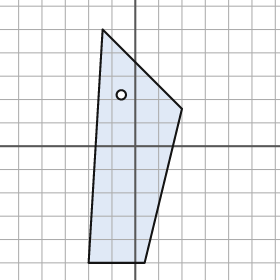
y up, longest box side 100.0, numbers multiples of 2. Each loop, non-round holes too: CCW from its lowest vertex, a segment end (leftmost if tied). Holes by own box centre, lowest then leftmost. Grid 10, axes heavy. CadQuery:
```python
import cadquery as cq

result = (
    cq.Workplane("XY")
    .moveTo(-20.0, -50.0)
    .lineTo(4.0, -50.0)
    .lineTo(20.0, 16.0)
    .lineTo(-14.0, 50.0)
    .close()
    .moveTo(-6.0, 22.0)
    .circle(2.0)
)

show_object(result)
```